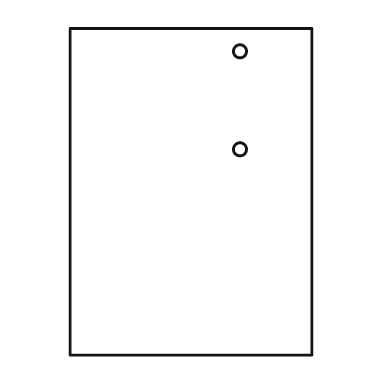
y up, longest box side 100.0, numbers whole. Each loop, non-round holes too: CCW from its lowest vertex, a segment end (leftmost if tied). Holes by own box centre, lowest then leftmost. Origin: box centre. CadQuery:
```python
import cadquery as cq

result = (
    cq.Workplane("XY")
    .moveTo(-37.0, -50.0)
    .lineTo(37.0, -50.0)
    .lineTo(37.0, 50.0)
    .lineTo(-37.0, 50.0)
    .close()
    .moveTo(15.0, 13.0)
    .circle(2.0)
    .moveTo(15.0, 43.0)
    .circle(2.0)
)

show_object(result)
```